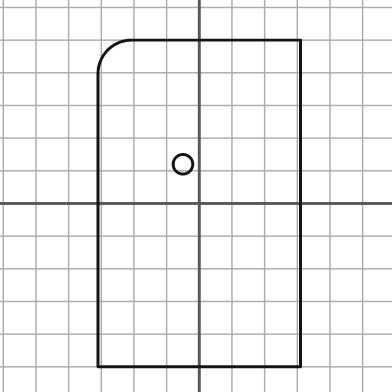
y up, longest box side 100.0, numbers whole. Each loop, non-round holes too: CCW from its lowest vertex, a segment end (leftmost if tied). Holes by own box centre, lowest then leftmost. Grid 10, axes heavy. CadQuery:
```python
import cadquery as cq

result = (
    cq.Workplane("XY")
    .moveTo(-31.0, -50.0)
    .lineTo(31.0, -50.0)
    .lineTo(31.0, 50.0)
    .lineTo(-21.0, 50.0)
    .threePointArc((-28.0, 47.0), (-31.0, 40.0))
    .close()
    .moveTo(-5.0, 12.0)
    .circle(3.0)
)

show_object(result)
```